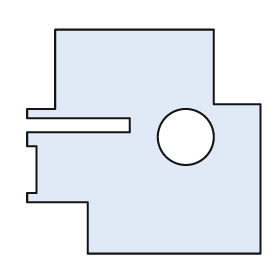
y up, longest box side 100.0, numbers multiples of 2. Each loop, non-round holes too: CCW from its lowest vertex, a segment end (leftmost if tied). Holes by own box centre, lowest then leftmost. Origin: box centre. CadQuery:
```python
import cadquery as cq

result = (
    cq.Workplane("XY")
    .moveTo(-24.0, -48.0)
    .lineTo(50.0, -48.0)
    .lineTo(50.0, 16.0)
    .lineTo(30.0, 16.0)
    .lineTo(30.0, 48.0)
    .lineTo(-38.0, 48.0)
    .lineTo(-38.0, 14.0)
    .lineTo(-50.0, 14.0)
    .lineTo(-50.0, 10.0)
    .lineTo(-6.0, 10.0)
    .lineTo(-6.0, 4.0)
    .lineTo(-50.0, 4.0)
    .lineTo(-50.0, -2.0)
    .lineTo(-46.0, -2.0)
    .lineTo(-46.0, -22.0)
    .lineTo(-50.0, -22.0)
    .lineTo(-50.0, -26.0)
    .lineTo(-24.0, -26.0)
    .close()
    .moveTo(18.0, 2.0)
    .circle(12.0)
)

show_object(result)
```